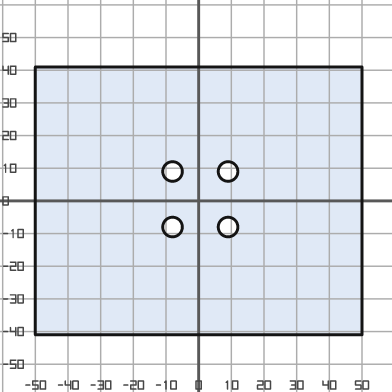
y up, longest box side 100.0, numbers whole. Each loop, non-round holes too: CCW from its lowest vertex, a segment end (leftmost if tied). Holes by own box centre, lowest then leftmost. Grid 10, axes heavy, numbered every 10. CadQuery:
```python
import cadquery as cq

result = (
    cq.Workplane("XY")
    .moveTo(-50.0, -41.0)
    .lineTo(50.0, -41.0)
    .lineTo(50.0, 41.0)
    .lineTo(-50.0, 41.0)
    .close()
    .moveTo(-8.0, -8.0)
    .circle(3.0)
    .moveTo(9.0, -8.0)
    .circle(3.0)
    .moveTo(-8.0, 9.0)
    .circle(3.0)
    .moveTo(9.0, 9.0)
    .circle(3.0)
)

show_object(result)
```